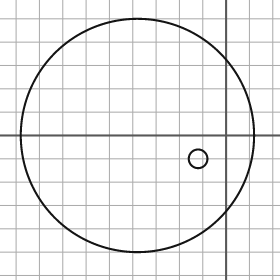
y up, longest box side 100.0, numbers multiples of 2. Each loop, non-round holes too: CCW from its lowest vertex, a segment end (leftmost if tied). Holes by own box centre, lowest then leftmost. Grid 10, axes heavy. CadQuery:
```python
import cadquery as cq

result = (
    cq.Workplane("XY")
    .moveTo(-38.0, 0.0)
    .circle(50.0)
    .moveTo(-12.0, -10.0)
    .circle(4.0)
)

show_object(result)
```